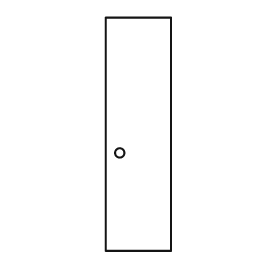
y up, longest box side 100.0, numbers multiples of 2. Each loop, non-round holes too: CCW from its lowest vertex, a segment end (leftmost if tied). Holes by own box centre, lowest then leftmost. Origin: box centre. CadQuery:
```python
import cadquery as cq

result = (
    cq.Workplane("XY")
    .moveTo(-14.0, -50.0)
    .lineTo(14.0, -50.0)
    .lineTo(14.0, 50.0)
    .lineTo(-14.0, 50.0)
    .close()
    .moveTo(-8.0, -8.0)
    .circle(2.0)
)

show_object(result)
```